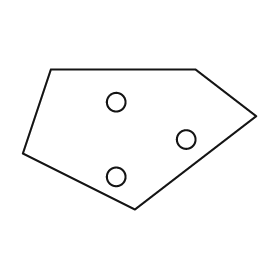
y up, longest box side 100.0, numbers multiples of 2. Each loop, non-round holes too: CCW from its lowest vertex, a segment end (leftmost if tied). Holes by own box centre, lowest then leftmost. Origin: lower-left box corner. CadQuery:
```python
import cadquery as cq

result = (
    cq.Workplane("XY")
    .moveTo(48.0, 0.0)
    .lineTo(100.0, 40.0)
    .lineTo(74.0, 60.0)
    .lineTo(12.0, 60.0)
    .lineTo(0.0, 24.0)
    .close()
    .moveTo(40.0, 14.0)
    .circle(4.0)
    .moveTo(70.0, 30.0)
    .circle(4.0)
    .moveTo(40.0, 46.0)
    .circle(4.0)
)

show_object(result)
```